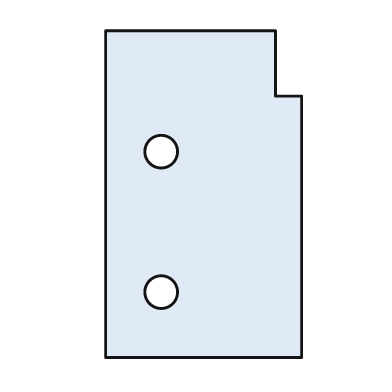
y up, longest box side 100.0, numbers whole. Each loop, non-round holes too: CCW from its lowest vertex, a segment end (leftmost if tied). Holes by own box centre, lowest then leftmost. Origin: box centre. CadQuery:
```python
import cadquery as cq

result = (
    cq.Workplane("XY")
    .moveTo(-30.0, -50.0)
    .lineTo(30.0, -50.0)
    .lineTo(30.0, 30.0)
    .lineTo(22.0, 30.0)
    .lineTo(22.0, 50.0)
    .lineTo(-30.0, 50.0)
    .close()
    .moveTo(-13.0, -30.0)
    .circle(5.0)
    .moveTo(-13.0, 13.0)
    .circle(5.0)
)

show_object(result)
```